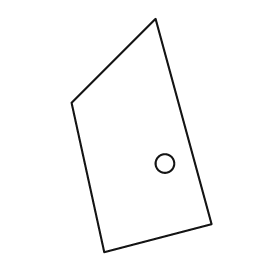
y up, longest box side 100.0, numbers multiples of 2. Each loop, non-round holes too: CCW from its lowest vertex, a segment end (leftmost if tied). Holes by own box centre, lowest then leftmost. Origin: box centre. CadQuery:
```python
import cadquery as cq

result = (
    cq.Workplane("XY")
    .moveTo(-16.0, -50.0)
    .lineTo(30.0, -38.0)
    .lineTo(6.0, 50.0)
    .lineTo(-30.0, 14.0)
    .close()
    .moveTo(10.0, -12.0)
    .circle(4.0)
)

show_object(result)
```